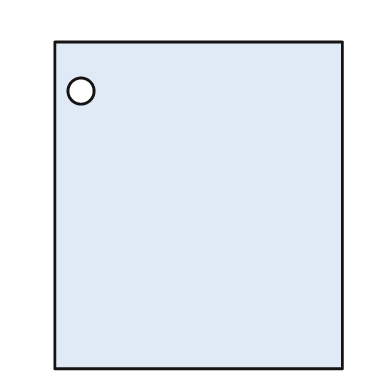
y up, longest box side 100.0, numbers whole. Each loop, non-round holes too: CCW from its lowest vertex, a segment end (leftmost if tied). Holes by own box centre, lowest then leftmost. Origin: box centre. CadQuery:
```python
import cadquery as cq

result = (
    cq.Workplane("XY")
    .moveTo(-44.0, -50.0)
    .lineTo(44.0, -50.0)
    .lineTo(44.0, 50.0)
    .lineTo(-44.0, 50.0)
    .close()
    .moveTo(-36.0, 35.0)
    .circle(4.0)
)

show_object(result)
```